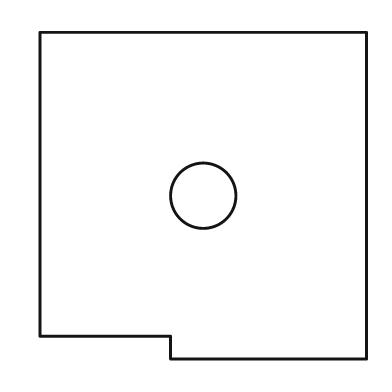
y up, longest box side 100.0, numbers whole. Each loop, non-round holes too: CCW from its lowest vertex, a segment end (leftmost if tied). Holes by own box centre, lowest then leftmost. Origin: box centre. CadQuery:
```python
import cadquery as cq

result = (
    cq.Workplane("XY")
    .moveTo(-10.0, -50.0)
    .lineTo(50.0, -50.0)
    .lineTo(50.0, 50.0)
    .lineTo(-50.0, 50.0)
    .lineTo(-50.0, -43.0)
    .lineTo(-10.0, -43.0)
    .close()
    .moveTo(0.0, 0.0)
    .circle(10.0)
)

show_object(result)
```